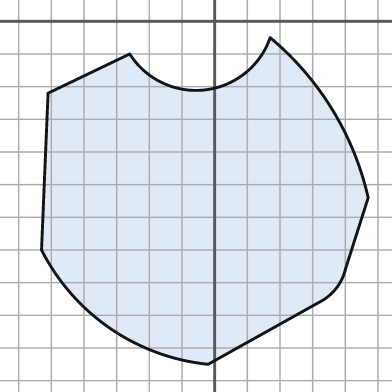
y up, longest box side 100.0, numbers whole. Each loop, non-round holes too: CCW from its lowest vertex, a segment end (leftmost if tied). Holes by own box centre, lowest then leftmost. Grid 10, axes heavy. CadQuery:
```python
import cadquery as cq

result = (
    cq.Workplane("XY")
    .moveTo(-2.0, -105.0)
    .lineTo(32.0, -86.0)
    .threePointArc((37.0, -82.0), (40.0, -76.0))
    .lineTo(47.0, -54.0)
    .threePointArc((36.0, -27.0), (17.0, -5.0))
    .threePointArc((-3.0, -21.0), (-26.0, -10.0))
    .lineTo(-51.0, -22.0)
    .lineTo(-53.0, -70.0)
    .threePointArc((-32.0, -94.0), (-2.0, -105.0))
    .close()
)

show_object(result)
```